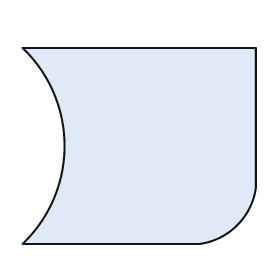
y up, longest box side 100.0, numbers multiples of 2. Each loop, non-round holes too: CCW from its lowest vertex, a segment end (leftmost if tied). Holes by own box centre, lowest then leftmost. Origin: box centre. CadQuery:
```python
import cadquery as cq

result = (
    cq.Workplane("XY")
    .moveTo(-50.0, -42.0)
    .lineTo(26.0, -42.0)
    .threePointArc((42.0, -34.0), (50.0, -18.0))
    .lineTo(50.0, 42.0)
    .lineTo(-50.0, 42.0)
    .threePointArc((-32.0, 0.0), (-50.0, -42.0))
    .close()
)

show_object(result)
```